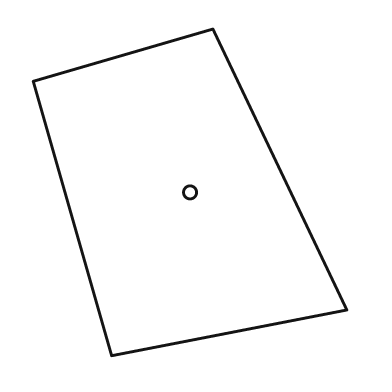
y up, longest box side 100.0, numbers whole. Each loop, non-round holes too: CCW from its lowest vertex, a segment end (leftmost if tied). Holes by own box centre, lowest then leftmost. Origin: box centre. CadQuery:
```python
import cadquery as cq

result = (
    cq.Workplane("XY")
    .moveTo(-24.0, -50.0)
    .lineTo(48.0, -36.0)
    .lineTo(7.0, 50.0)
    .lineTo(-48.0, 34.0)
    .close()
    .moveTo(0.0, 0.0)
    .circle(2.0)
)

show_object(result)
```